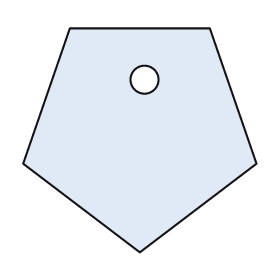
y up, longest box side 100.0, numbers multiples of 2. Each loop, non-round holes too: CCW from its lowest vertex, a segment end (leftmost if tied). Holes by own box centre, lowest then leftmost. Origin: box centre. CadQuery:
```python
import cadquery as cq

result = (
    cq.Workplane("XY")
    .moveTo(0.0, -48.0)
    .lineTo(50.0, -10.0)
    .lineTo(30.0, 48.0)
    .lineTo(-30.0, 48.0)
    .lineTo(-50.0, -10.0)
    .close()
    .moveTo(2.0, 26.0)
    .circle(6.0)
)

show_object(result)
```